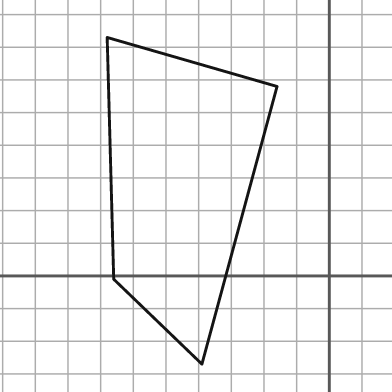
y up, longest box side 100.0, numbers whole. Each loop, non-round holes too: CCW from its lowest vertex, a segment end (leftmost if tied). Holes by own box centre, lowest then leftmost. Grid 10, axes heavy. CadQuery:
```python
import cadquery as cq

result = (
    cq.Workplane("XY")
    .moveTo(-39.0, -27.0)
    .lineTo(-16.0, 58.0)
    .lineTo(-68.0, 73.0)
    .lineTo(-66.0, -1.0)
    .close()
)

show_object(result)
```